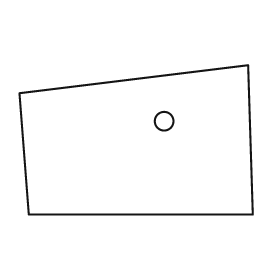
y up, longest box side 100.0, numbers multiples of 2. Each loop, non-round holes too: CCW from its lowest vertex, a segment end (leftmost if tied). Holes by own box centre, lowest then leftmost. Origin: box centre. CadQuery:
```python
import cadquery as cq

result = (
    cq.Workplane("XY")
    .moveTo(-46.0, -32.0)
    .lineTo(50.0, -32.0)
    .lineTo(48.0, 32.0)
    .lineTo(-50.0, 20.0)
    .close()
    .moveTo(12.0, 8.0)
    .circle(4.0)
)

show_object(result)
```